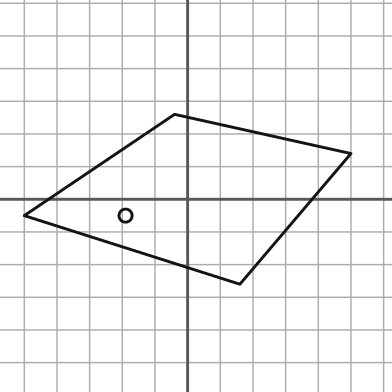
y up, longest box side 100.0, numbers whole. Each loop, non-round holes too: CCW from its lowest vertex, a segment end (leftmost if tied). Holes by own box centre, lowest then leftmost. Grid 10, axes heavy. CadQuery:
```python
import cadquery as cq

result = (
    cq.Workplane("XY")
    .moveTo(16.0, -26.0)
    .lineTo(50.0, 14.0)
    .lineTo(-4.0, 26.0)
    .lineTo(-50.0, -5.0)
    .close()
    .moveTo(-19.0, -5.0)
    .circle(2.0)
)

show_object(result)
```